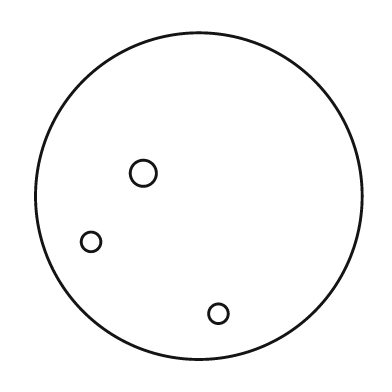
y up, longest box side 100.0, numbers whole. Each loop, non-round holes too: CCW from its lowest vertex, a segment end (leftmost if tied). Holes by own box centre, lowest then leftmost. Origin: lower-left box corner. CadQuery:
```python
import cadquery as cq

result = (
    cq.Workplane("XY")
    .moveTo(50.0, 50.0)
    .circle(50.0)
    .moveTo(56.0, 14.0)
    .circle(3.0)
    .moveTo(17.0, 36.0)
    .circle(3.0)
    .moveTo(33.0, 57.0)
    .circle(4.0)
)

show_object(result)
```